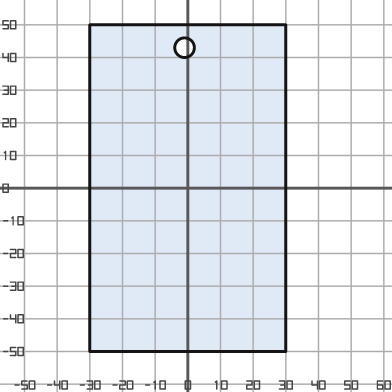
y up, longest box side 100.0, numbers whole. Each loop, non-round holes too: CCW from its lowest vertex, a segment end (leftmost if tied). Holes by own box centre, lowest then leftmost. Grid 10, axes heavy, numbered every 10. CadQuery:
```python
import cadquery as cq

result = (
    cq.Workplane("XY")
    .moveTo(-30.0, -50.0)
    .lineTo(30.0, -50.0)
    .lineTo(30.0, 50.0)
    .lineTo(-30.0, 50.0)
    .close()
    .moveTo(-1.0, 43.0)
    .circle(3.0)
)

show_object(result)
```